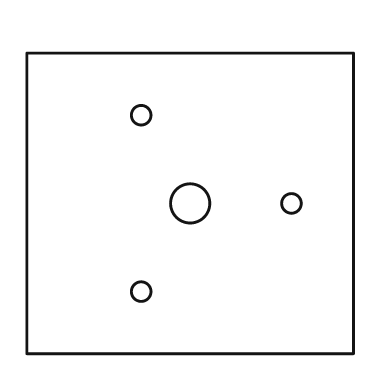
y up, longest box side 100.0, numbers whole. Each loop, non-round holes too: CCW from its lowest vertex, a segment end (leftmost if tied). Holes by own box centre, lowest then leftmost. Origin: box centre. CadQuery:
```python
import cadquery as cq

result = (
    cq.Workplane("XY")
    .moveTo(-50.0, -46.0)
    .lineTo(50.0, -46.0)
    .lineTo(50.0, 46.0)
    .lineTo(-50.0, 46.0)
    .close()
    .moveTo(-15.0, -27.0)
    .circle(3.0)
    .moveTo(0.0, 0.0)
    .circle(6.0)
    .moveTo(31.0, 0.0)
    .circle(3.0)
    .moveTo(-15.0, 27.0)
    .circle(3.0)
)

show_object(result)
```